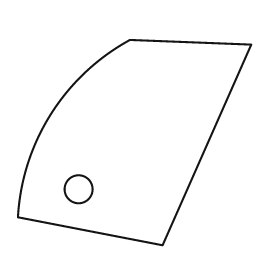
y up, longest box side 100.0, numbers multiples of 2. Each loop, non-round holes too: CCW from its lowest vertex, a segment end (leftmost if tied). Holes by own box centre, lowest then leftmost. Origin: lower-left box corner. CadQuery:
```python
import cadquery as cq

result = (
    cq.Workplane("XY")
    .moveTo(62.0, 0.0)
    .lineTo(100.0, 86.0)
    .lineTo(48.0, 88.0)
    .threePointArc((14.0, 56.0), (0.0, 12.0))
    .close()
    .moveTo(26.0, 24.0)
    .circle(6.0)
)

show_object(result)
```